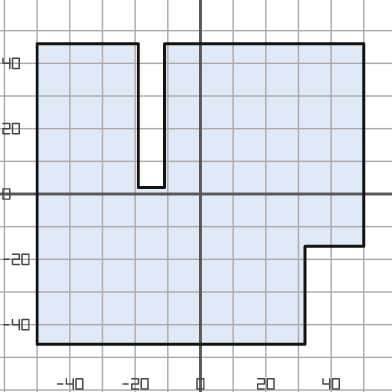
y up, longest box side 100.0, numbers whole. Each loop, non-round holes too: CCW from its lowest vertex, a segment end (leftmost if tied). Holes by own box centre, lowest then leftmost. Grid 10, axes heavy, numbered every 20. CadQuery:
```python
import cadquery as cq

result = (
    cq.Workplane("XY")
    .moveTo(-50.0, -46.0)
    .lineTo(32.0, -46.0)
    .lineTo(32.0, -16.0)
    .lineTo(50.0, -16.0)
    .lineTo(50.0, 46.0)
    .lineTo(-11.0, 46.0)
    .lineTo(-11.0, 2.0)
    .lineTo(-19.0, 2.0)
    .lineTo(-19.0, 46.0)
    .lineTo(-50.0, 46.0)
    .close()
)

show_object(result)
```